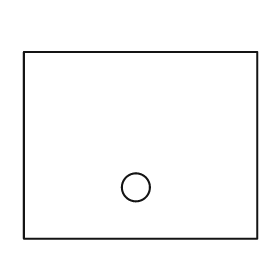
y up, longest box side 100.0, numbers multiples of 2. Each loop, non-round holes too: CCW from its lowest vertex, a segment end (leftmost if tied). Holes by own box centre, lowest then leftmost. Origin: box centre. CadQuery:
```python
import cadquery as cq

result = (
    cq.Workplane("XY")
    .moveTo(-50.0, -40.0)
    .lineTo(50.0, -40.0)
    .lineTo(50.0, 40.0)
    .lineTo(-50.0, 40.0)
    .close()
    .moveTo(-2.0, -18.0)
    .circle(6.0)
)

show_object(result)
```